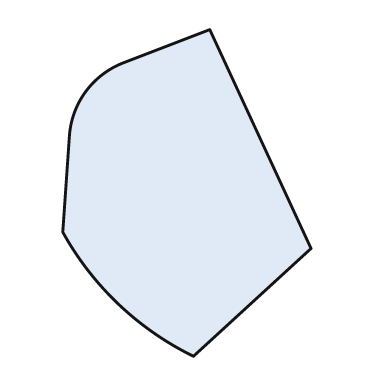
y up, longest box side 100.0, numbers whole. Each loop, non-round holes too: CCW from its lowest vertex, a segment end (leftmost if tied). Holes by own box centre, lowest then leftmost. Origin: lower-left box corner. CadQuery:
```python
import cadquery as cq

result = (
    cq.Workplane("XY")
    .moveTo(40.0, 0.0)
    .lineTo(76.0, 33.0)
    .lineTo(45.0, 100.0)
    .lineTo(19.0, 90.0)
    .threePointArc((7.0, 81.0), (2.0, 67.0))
    .lineTo(0.0, 38.0)
    .threePointArc((17.0, 16.0), (40.0, 0.0))
    .close()
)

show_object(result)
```